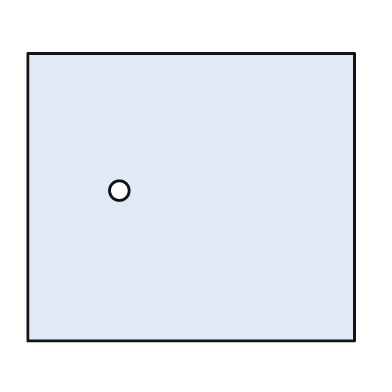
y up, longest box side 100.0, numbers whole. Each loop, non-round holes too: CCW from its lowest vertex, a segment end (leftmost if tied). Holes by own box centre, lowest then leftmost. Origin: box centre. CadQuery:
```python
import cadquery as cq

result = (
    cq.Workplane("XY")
    .moveTo(-50.0, -44.0)
    .lineTo(50.0, -44.0)
    .lineTo(50.0, 44.0)
    .lineTo(-50.0, 44.0)
    .close()
    .moveTo(-22.0, 2.0)
    .circle(3.0)
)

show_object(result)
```